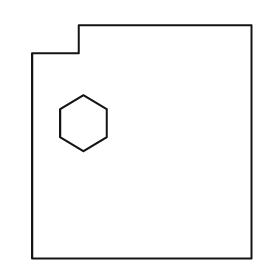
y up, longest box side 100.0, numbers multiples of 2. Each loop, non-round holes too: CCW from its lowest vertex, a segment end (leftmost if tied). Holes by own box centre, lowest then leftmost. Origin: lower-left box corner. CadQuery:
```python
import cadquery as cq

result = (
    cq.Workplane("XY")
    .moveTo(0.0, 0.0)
    .lineTo(94.0, 0.0)
    .lineTo(94.0, 100.0)
    .lineTo(20.0, 100.0)
    .lineTo(20.0, 88.0)
    .lineTo(0.0, 88.0)
    .close()
    .moveTo(22.0, 46.0)
    .lineTo(32.0, 52.0)
    .lineTo(32.0, 64.0)
    .lineTo(22.0, 70.0)
    .lineTo(12.0, 64.0)
    .lineTo(12.0, 52.0)
    .close()
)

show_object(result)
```